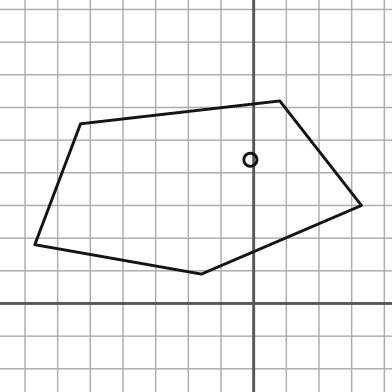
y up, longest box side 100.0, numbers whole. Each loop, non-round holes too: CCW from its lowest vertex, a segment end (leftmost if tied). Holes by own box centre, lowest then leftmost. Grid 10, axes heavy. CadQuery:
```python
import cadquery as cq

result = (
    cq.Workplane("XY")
    .moveTo(-16.0, 9.0)
    .lineTo(33.0, 30.0)
    .lineTo(8.0, 62.0)
    .lineTo(-53.0, 55.0)
    .lineTo(-67.0, 18.0)
    .close()
    .moveTo(-1.0, 44.0)
    .circle(2.0)
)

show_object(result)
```